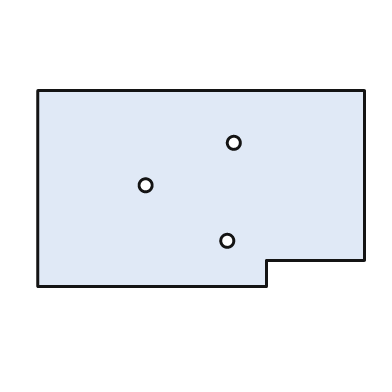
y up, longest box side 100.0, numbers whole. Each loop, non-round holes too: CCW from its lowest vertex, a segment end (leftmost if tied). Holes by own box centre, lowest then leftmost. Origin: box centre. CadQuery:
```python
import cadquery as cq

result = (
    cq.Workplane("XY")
    .moveTo(-50.0, -30.0)
    .lineTo(20.0, -30.0)
    .lineTo(20.0, -22.0)
    .lineTo(50.0, -22.0)
    .lineTo(50.0, 30.0)
    .lineTo(-50.0, 30.0)
    .close()
    .moveTo(8.0, -16.0)
    .circle(2.0)
    .moveTo(-17.0, 1.0)
    .circle(2.0)
    .moveTo(10.0, 14.0)
    .circle(2.0)
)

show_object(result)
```